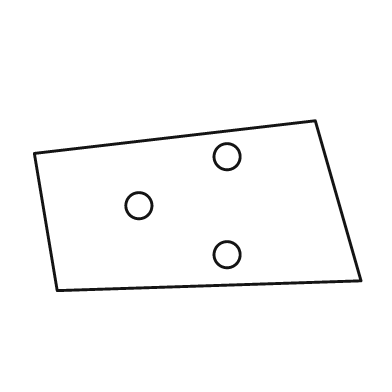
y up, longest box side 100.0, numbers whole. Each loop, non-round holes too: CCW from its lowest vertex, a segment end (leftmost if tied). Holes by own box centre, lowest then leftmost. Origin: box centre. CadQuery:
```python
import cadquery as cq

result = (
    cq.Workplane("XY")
    .moveTo(-43.0, -26.0)
    .lineTo(50.0, -23.0)
    .lineTo(36.0, 26.0)
    .lineTo(-50.0, 16.0)
    .close()
    .moveTo(9.0, -15.0)
    .circle(4.0)
    .moveTo(-18.0, 0.0)
    .circle(4.0)
    .moveTo(9.0, 15.0)
    .circle(4.0)
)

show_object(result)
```